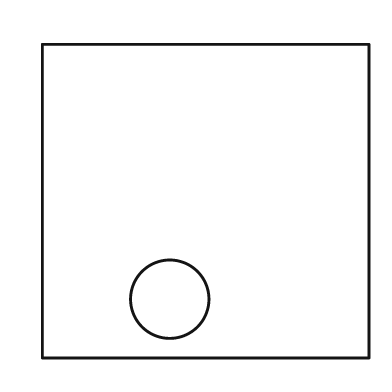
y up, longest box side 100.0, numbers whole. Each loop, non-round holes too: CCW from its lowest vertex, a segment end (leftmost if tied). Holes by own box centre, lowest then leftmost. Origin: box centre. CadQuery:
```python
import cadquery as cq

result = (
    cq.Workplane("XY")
    .moveTo(-50.0, -48.0)
    .lineTo(50.0, -48.0)
    .lineTo(50.0, 48.0)
    .lineTo(-50.0, 48.0)
    .close()
    .moveTo(-11.0, -30.0)
    .circle(12.0)
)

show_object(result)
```